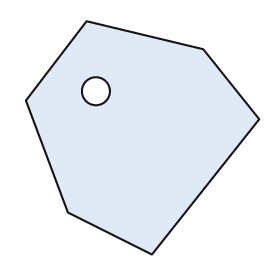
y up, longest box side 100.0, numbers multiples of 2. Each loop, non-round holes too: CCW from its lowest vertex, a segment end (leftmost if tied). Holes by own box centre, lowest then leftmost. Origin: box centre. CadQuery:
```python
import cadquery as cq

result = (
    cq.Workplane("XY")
    .moveTo(4.0, -50.0)
    .lineTo(50.0, 8.0)
    .lineTo(26.0, 38.0)
    .lineTo(-24.0, 50.0)
    .lineTo(-50.0, 16.0)
    .lineTo(-32.0, -32.0)
    .close()
    .moveTo(-20.0, 20.0)
    .circle(6.0)
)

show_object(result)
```